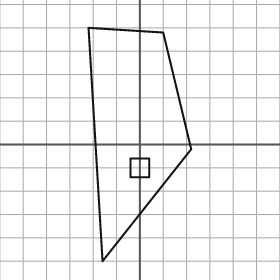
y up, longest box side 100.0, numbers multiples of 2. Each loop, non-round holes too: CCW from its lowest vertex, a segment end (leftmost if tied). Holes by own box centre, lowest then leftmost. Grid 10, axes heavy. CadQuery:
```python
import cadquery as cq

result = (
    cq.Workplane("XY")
    .moveTo(-16.0, -50.0)
    .lineTo(22.0, -2.0)
    .lineTo(10.0, 48.0)
    .lineTo(-22.0, 50.0)
    .close()
    .moveTo(-4.0, -14.0)
    .lineTo(4.0, -14.0)
    .lineTo(4.0, -6.0)
    .lineTo(-4.0, -6.0)
    .close()
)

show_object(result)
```